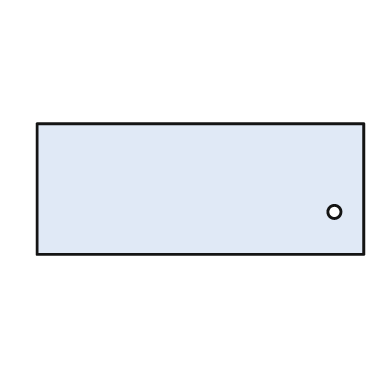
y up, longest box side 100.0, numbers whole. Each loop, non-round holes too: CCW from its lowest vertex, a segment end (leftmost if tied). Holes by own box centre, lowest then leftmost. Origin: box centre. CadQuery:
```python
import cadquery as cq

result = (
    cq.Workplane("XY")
    .moveTo(-50.0, -20.0)
    .lineTo(50.0, -20.0)
    .lineTo(50.0, 20.0)
    .lineTo(-50.0, 20.0)
    .close()
    .moveTo(41.0, -7.0)
    .circle(2.0)
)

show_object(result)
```